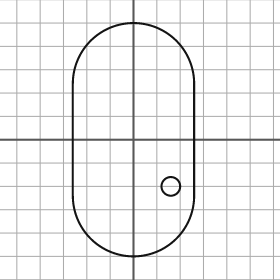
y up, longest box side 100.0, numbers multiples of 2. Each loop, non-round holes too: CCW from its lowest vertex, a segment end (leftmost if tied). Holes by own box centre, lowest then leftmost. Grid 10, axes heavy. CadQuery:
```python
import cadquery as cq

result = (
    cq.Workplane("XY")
    .moveTo(-26.0, -24.0)
    .threePointArc((0.0, -50.0), (26.0, -24.0))
    .lineTo(26.0, 24.0)
    .threePointArc((0.0, 50.0), (-26.0, 24.0))
    .close()
    .moveTo(16.0, -20.0)
    .circle(4.0)
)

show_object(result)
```